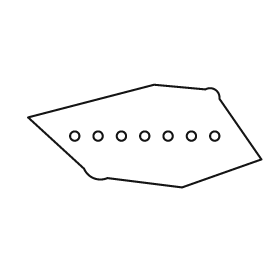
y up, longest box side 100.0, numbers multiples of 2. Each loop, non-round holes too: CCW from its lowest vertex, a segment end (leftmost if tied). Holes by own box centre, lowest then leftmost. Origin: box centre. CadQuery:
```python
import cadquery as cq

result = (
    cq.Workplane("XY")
    .moveTo(16.0, -22.0)
    .lineTo(50.0, -10.0)
    .lineTo(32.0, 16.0)
    .threePointArc((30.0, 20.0), (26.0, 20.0))
    .lineTo(4.0, 22.0)
    .lineTo(-50.0, 8.0)
    .lineTo(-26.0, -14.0)
    .threePointArc((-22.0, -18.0), (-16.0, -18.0))
    .close()
    .moveTo(-30.0, 0.0)
    .circle(2.0)
    .moveTo(-20.0, 0.0)
    .circle(2.0)
    .moveTo(-10.0, 0.0)
    .circle(2.0)
    .moveTo(0.0, 0.0)
    .circle(2.0)
    .moveTo(10.0, 0.0)
    .circle(2.0)
    .moveTo(20.0, 0.0)
    .circle(2.0)
    .moveTo(30.0, 0.0)
    .circle(2.0)
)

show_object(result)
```